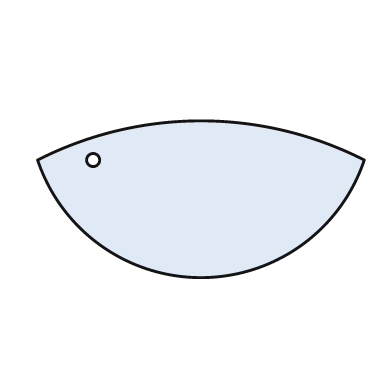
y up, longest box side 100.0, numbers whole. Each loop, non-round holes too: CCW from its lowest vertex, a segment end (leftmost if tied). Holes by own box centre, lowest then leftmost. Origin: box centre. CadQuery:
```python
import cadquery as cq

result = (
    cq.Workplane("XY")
    .moveTo(-50.0, 12.0)
    .threePointArc((0.0, -24.0), (50.0, 12.0))
    .threePointArc((0.0, 24.0), (-50.0, 12.0))
    .close()
    .moveTo(-33.0, 12.0)
    .circle(2.0)
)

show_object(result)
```